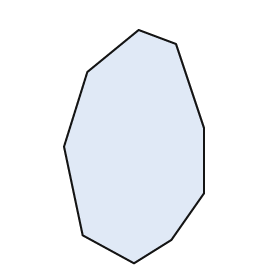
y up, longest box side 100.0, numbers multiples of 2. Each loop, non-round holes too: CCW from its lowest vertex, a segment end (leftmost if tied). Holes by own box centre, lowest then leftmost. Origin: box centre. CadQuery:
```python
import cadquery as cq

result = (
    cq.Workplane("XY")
    .moveTo(0.0, -50.0)
    .lineTo(16.0, -40.0)
    .lineTo(30.0, -20.0)
    .lineTo(30.0, 8.0)
    .lineTo(18.0, 44.0)
    .lineTo(2.0, 50.0)
    .lineTo(-20.0, 32.0)
    .lineTo(-30.0, 0.0)
    .lineTo(-22.0, -38.0)
    .close()
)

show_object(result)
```